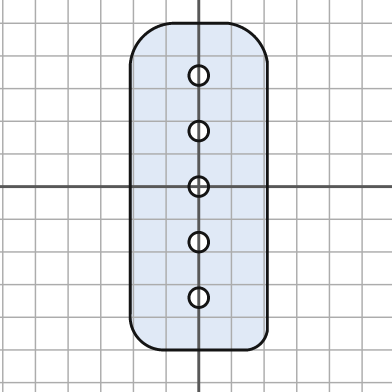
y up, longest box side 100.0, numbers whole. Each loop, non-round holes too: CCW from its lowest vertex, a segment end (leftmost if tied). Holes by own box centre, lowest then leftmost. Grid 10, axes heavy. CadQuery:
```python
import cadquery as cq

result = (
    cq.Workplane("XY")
    .moveTo(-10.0, -50.0)
    .lineTo(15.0, -50.0)
    .threePointArc((19.0, -48.0), (21.0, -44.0))
    .lineTo(21.0, 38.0)
    .threePointArc((17.0, 46.0), (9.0, 50.0))
    .lineTo(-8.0, 50.0)
    .threePointArc((-17.0, 46.0), (-21.0, 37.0))
    .lineTo(-21.0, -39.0)
    .threePointArc((-18.0, -47.0), (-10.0, -50.0))
    .close()
    .moveTo(0.0, -34.0)
    .circle(3.0)
    .moveTo(0.0, -17.0)
    .circle(3.0)
    .moveTo(0.0, 0.0)
    .circle(3.0)
    .moveTo(0.0, 17.0)
    .circle(3.0)
    .moveTo(0.0, 34.0)
    .circle(3.0)
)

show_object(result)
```